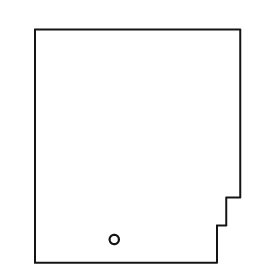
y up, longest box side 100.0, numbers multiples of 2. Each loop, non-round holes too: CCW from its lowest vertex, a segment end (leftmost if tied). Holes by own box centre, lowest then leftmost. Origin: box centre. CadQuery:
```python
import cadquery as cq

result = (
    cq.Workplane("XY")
    .moveTo(-44.0, -50.0)
    .lineTo(34.0, -50.0)
    .lineTo(34.0, -34.0)
    .lineTo(38.0, -34.0)
    .lineTo(38.0, -22.0)
    .lineTo(44.0, -22.0)
    .lineTo(44.0, 50.0)
    .lineTo(-44.0, 50.0)
    .close()
    .moveTo(-10.0, -40.0)
    .circle(2.0)
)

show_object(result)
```